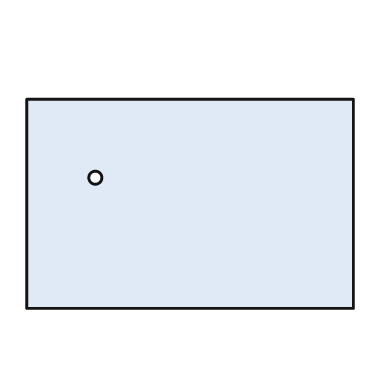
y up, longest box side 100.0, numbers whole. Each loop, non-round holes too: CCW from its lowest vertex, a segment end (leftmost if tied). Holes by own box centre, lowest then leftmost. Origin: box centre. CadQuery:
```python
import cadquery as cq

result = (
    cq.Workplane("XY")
    .moveTo(-50.0, -32.0)
    .lineTo(50.0, -32.0)
    .lineTo(50.0, 32.0)
    .lineTo(-50.0, 32.0)
    .close()
    .moveTo(-29.0, 8.0)
    .circle(2.0)
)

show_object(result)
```